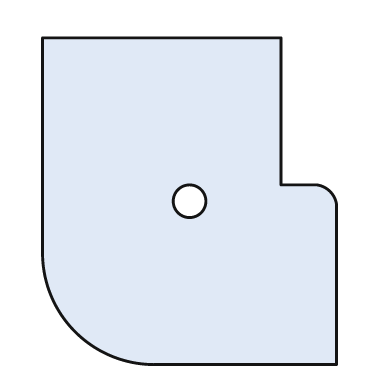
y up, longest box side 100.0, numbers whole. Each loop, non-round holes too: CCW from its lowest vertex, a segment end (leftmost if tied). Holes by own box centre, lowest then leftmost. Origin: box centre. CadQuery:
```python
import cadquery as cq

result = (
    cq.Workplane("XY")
    .moveTo(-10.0, -50.0)
    .lineTo(45.0, -50.0)
    .lineTo(45.0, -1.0)
    .threePointArc((43.0, 3.0), (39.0, 5.0))
    .lineTo(28.0, 5.0)
    .lineTo(28.0, 50.0)
    .lineTo(-45.0, 50.0)
    .lineTo(-45.0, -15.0)
    .threePointArc((-35.0, -40.0), (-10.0, -50.0))
    .close()
    .moveTo(0.0, 0.0)
    .circle(5.0)
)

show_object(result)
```